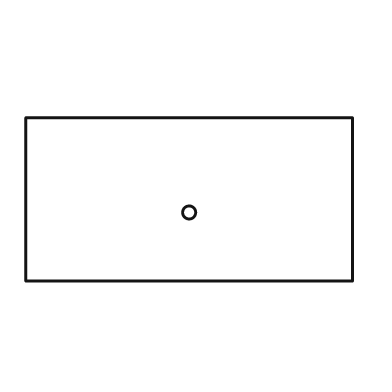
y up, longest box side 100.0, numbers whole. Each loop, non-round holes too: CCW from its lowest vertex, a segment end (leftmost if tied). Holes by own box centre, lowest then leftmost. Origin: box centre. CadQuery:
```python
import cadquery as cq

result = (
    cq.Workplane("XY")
    .moveTo(-50.0, -25.0)
    .lineTo(50.0, -25.0)
    .lineTo(50.0, 25.0)
    .lineTo(-50.0, 25.0)
    .close()
    .moveTo(0.0, -4.0)
    .circle(2.0)
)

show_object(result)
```